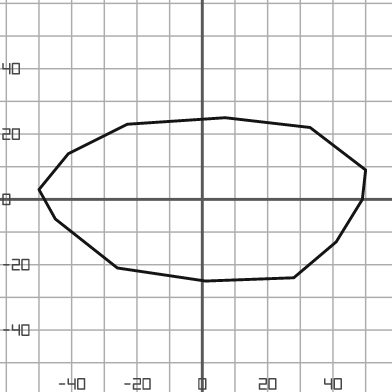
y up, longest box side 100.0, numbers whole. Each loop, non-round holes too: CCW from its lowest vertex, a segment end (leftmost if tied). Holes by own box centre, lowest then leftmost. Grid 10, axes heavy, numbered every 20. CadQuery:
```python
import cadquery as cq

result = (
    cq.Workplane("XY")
    .moveTo(1.0, -25.0)
    .lineTo(28.0, -24.0)
    .lineTo(41.0, -13.0)
    .lineTo(49.0, 0.0)
    .lineTo(50.0, 9.0)
    .lineTo(33.0, 22.0)
    .lineTo(7.0, 25.0)
    .lineTo(-23.0, 23.0)
    .lineTo(-41.0, 14.0)
    .lineTo(-50.0, 3.0)
    .lineTo(-45.0, -6.0)
    .lineTo(-26.0, -21.0)
    .close()
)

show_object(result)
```